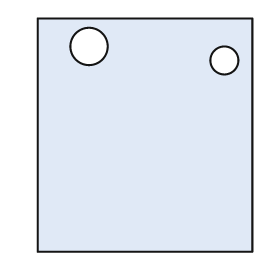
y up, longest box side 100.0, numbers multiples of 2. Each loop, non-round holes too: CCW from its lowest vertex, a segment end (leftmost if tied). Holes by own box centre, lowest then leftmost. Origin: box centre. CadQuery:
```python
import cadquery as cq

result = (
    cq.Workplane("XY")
    .moveTo(-46.0, -50.0)
    .lineTo(46.0, -50.0)
    .lineTo(46.0, 50.0)
    .lineTo(-46.0, 50.0)
    .close()
    .moveTo(34.0, 32.0)
    .circle(6.0)
    .moveTo(-24.0, 38.0)
    .circle(8.0)
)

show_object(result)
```